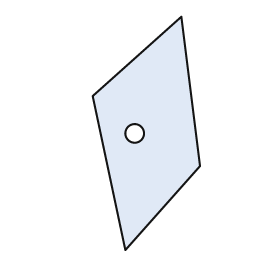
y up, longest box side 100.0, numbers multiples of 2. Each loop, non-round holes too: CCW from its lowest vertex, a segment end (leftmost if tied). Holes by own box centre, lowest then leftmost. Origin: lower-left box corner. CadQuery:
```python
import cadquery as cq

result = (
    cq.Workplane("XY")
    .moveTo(14.0, 0.0)
    .lineTo(46.0, 36.0)
    .lineTo(38.0, 100.0)
    .lineTo(0.0, 66.0)
    .close()
    .moveTo(18.0, 50.0)
    .circle(4.0)
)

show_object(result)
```